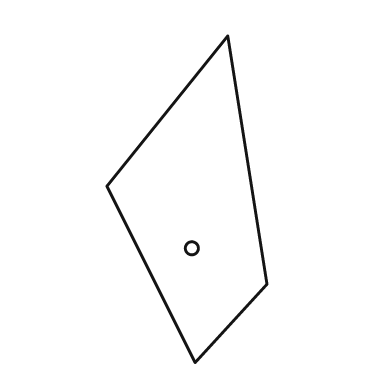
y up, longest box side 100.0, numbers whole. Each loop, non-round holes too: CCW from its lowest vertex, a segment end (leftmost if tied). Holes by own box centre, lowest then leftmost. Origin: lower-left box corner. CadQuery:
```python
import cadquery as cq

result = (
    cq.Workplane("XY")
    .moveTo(27.0, 0.0)
    .lineTo(49.0, 24.0)
    .lineTo(37.0, 100.0)
    .lineTo(0.0, 54.0)
    .close()
    .moveTo(26.0, 35.0)
    .circle(2.0)
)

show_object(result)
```